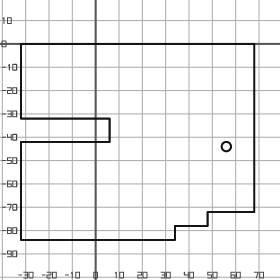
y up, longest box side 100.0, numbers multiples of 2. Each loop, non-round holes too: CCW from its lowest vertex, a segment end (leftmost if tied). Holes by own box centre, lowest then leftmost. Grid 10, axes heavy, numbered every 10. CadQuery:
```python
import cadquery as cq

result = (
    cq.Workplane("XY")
    .moveTo(-32.0, -84.0)
    .lineTo(34.0, -84.0)
    .lineTo(34.0, -78.0)
    .lineTo(48.0, -78.0)
    .lineTo(48.0, -72.0)
    .lineTo(68.0, -72.0)
    .lineTo(68.0, 0.0)
    .lineTo(-32.0, 0.0)
    .lineTo(-32.0, -32.0)
    .lineTo(6.0, -32.0)
    .lineTo(6.0, -42.0)
    .lineTo(-32.0, -42.0)
    .close()
    .moveTo(56.0, -44.0)
    .circle(2.0)
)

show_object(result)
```